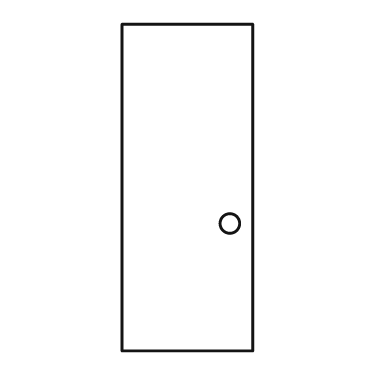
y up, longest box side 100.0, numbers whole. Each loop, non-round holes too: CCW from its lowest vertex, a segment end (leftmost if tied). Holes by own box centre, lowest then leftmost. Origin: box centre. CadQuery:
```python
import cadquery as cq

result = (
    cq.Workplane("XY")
    .moveTo(-20.0, -50.0)
    .lineTo(20.0, -50.0)
    .lineTo(20.0, 50.0)
    .lineTo(-20.0, 50.0)
    .close()
    .moveTo(13.0, -11.0)
    .circle(3.0)
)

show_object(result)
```